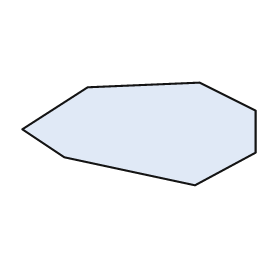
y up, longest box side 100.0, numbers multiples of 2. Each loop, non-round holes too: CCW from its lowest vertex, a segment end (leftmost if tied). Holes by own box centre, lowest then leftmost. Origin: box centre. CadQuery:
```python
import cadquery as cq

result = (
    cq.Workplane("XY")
    .moveTo(24.0, -22.0)
    .lineTo(50.0, -8.0)
    .lineTo(50.0, 10.0)
    .lineTo(26.0, 22.0)
    .lineTo(-22.0, 20.0)
    .lineTo(-50.0, 2.0)
    .lineTo(-32.0, -10.0)
    .close()
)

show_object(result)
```